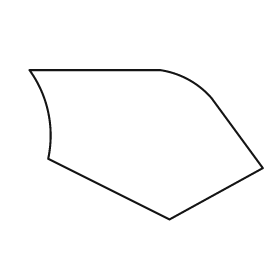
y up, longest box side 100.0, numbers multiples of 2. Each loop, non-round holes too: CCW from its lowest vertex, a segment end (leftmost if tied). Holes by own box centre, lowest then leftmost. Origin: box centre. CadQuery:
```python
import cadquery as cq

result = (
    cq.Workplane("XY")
    .moveTo(10.0, -32.0)
    .lineTo(50.0, -10.0)
    .lineTo(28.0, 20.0)
    .threePointArc((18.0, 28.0), (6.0, 32.0))
    .lineTo(-50.0, 32.0)
    .threePointArc((-42.0, 14.0), (-42.0, -6.0))
    .close()
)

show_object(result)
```